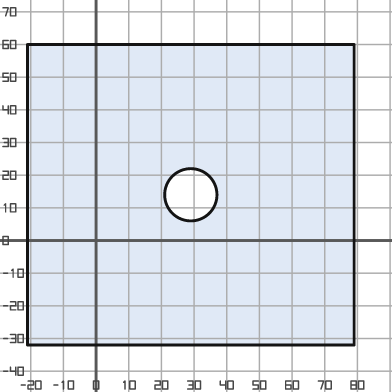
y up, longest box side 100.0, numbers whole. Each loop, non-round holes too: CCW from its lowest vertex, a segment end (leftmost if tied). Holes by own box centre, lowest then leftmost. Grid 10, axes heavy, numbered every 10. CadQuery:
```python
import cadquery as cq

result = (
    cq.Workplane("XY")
    .moveTo(-21.0, -32.0)
    .lineTo(79.0, -32.0)
    .lineTo(79.0, 60.0)
    .lineTo(-21.0, 60.0)
    .close()
    .moveTo(29.0, 14.0)
    .circle(8.0)
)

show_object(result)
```